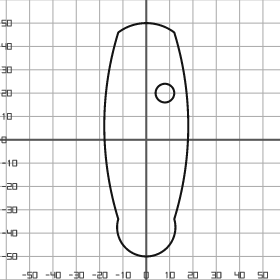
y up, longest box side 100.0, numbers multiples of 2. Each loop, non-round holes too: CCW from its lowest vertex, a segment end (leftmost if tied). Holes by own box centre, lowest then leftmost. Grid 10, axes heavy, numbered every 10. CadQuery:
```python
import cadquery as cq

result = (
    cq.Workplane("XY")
    .moveTo(-12.0, -34.0)
    .threePointArc((0.0, -50.0), (12.0, -34.0))
    .threePointArc((18.0, 6.0), (12.0, 46.0))
    .threePointArc((0.0, 50.0), (-12.0, 46.0))
    .threePointArc((-18.0, 6.0), (-12.0, -34.0))
    .close()
    .moveTo(8.0, 20.0)
    .circle(4.0)
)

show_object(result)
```